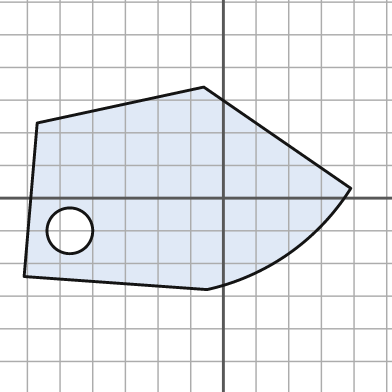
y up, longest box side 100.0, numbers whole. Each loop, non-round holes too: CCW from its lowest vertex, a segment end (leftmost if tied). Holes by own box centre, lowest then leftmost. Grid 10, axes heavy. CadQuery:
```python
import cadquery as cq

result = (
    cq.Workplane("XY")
    .moveTo(-5.0, -28.0)
    .threePointArc((20.0, -17.0), (39.0, 3.0))
    .lineTo(-6.0, 34.0)
    .lineTo(-57.0, 23.0)
    .lineTo(-61.0, -24.0)
    .close()
    .moveTo(-47.0, -10.0)
    .circle(7.0)
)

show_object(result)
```